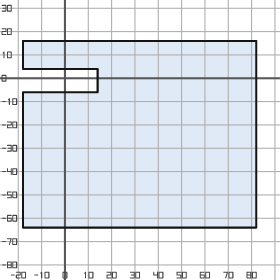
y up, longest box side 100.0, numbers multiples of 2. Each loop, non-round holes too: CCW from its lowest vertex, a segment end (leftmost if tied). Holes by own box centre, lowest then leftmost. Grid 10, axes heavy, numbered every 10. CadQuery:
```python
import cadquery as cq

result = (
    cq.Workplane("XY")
    .moveTo(-18.0, -64.0)
    .lineTo(82.0, -64.0)
    .lineTo(82.0, 16.0)
    .lineTo(-18.0, 16.0)
    .lineTo(-18.0, 4.0)
    .lineTo(14.0, 4.0)
    .lineTo(14.0, -6.0)
    .lineTo(-18.0, -6.0)
    .close()
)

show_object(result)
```